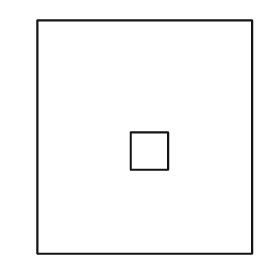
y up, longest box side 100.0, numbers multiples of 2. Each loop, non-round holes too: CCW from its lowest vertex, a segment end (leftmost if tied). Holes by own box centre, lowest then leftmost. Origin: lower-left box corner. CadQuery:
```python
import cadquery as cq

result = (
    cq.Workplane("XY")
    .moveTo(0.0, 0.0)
    .lineTo(92.0, 0.0)
    .lineTo(92.0, 100.0)
    .lineTo(0.0, 100.0)
    .close()
    .moveTo(40.0, 36.0)
    .lineTo(56.0, 36.0)
    .lineTo(56.0, 52.0)
    .lineTo(40.0, 52.0)
    .close()
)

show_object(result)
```